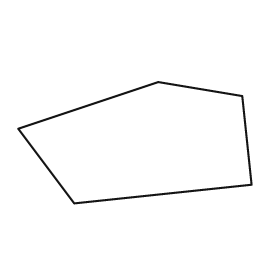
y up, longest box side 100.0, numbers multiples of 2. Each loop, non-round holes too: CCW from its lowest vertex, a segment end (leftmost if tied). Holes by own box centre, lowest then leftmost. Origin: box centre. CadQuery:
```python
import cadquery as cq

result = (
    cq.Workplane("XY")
    .moveTo(-26.0, -26.0)
    .lineTo(50.0, -18.0)
    .lineTo(46.0, 20.0)
    .lineTo(10.0, 26.0)
    .lineTo(-50.0, 6.0)
    .close()
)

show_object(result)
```